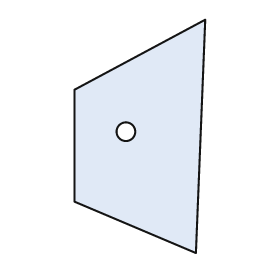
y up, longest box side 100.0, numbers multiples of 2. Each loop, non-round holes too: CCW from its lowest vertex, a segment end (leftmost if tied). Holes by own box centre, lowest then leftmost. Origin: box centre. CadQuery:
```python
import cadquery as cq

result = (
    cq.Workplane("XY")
    .moveTo(24.0, -50.0)
    .lineTo(28.0, 50.0)
    .lineTo(-28.0, 20.0)
    .lineTo(-28.0, -28.0)
    .close()
    .moveTo(-6.0, 2.0)
    .circle(4.0)
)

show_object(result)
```